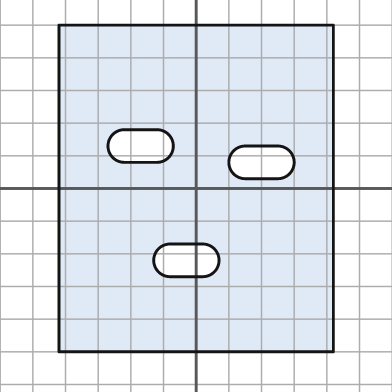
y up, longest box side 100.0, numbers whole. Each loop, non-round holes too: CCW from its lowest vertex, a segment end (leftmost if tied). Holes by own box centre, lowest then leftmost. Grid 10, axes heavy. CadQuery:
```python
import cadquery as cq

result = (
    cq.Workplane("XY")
    .moveTo(-42.0, -50.0)
    .lineTo(42.0, -50.0)
    .lineTo(42.0, 50.0)
    .lineTo(-42.0, 50.0)
    .close()
    .moveTo(-8.0, -27.0)
    .lineTo(2.0, -27.0)
    .threePointArc((7.0, -22.0), (2.0, -17.0))
    .lineTo(-8.0, -17.0)
    .threePointArc((-13.0, -22.0), (-8.0, -27.0))
    .close()
    .moveTo(15.0, 3.0)
    .lineTo(25.0, 3.0)
    .threePointArc((30.0, 8.0), (25.0, 13.0))
    .lineTo(15.0, 13.0)
    .threePointArc((10.0, 8.0), (15.0, 3.0))
    .close()
    .moveTo(-22.0, 8.0)
    .lineTo(-12.0, 8.0)
    .threePointArc((-7.0, 13.0), (-12.0, 18.0))
    .lineTo(-22.0, 18.0)
    .threePointArc((-27.0, 13.0), (-22.0, 8.0))
    .close()
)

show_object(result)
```